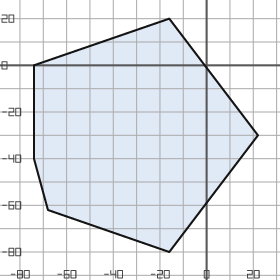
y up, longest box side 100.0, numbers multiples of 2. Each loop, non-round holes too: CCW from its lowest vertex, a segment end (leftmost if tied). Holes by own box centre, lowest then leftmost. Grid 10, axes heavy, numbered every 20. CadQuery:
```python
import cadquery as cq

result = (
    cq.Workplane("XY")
    .moveTo(-16.0, -80.0)
    .lineTo(22.0, -30.0)
    .lineTo(-16.0, 20.0)
    .lineTo(-74.0, 0.0)
    .lineTo(-74.0, -40.0)
    .lineTo(-68.0, -62.0)
    .close()
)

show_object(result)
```